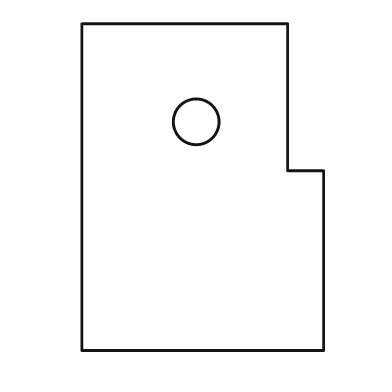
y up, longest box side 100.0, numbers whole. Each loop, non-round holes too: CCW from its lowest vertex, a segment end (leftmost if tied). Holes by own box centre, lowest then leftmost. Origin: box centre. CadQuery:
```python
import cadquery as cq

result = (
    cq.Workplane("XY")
    .moveTo(-37.0, -50.0)
    .lineTo(37.0, -50.0)
    .lineTo(37.0, 5.0)
    .lineTo(26.0, 5.0)
    .lineTo(26.0, 50.0)
    .lineTo(-37.0, 50.0)
    .close()
    .moveTo(-2.0, 20.0)
    .circle(7.0)
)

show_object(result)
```